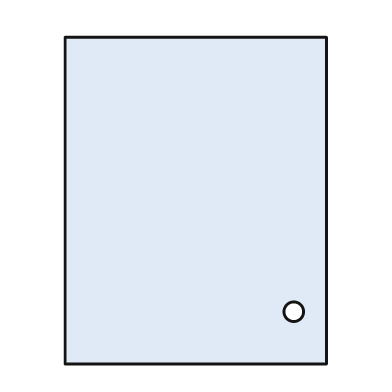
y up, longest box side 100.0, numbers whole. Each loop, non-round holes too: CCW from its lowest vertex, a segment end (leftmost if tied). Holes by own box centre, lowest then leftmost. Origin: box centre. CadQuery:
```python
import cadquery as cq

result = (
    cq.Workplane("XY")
    .moveTo(-40.0, -50.0)
    .lineTo(40.0, -50.0)
    .lineTo(40.0, 50.0)
    .lineTo(-40.0, 50.0)
    .close()
    .moveTo(30.0, -34.0)
    .circle(3.0)
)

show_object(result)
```